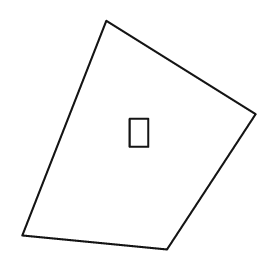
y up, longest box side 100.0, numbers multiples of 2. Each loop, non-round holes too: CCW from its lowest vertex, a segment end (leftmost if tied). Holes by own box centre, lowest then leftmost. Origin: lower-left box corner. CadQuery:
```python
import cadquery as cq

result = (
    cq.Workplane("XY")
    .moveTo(62.0, 0.0)
    .lineTo(100.0, 58.0)
    .lineTo(36.0, 98.0)
    .lineTo(0.0, 6.0)
    .close()
    .moveTo(46.0, 44.0)
    .lineTo(54.0, 44.0)
    .lineTo(54.0, 56.0)
    .lineTo(46.0, 56.0)
    .close()
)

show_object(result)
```